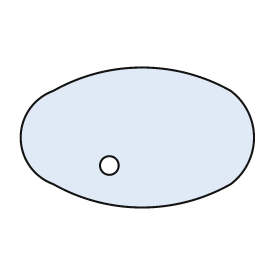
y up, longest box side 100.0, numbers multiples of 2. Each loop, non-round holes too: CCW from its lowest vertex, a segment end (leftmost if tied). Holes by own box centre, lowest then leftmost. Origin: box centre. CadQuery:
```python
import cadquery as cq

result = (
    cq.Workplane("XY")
    .moveTo(-36.0, -20.0)
    .threePointArc((2.0, -30.0), (40.0, -20.0))
    .threePointArc((50.0, 0.0), (40.0, 20.0))
    .threePointArc((2.0, 30.0), (-36.0, 20.0))
    .threePointArc((-50.0, 0.0), (-36.0, -20.0))
    .close()
    .moveTo(-12.0, -12.0)
    .circle(4.0)
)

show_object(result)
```